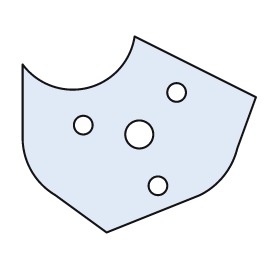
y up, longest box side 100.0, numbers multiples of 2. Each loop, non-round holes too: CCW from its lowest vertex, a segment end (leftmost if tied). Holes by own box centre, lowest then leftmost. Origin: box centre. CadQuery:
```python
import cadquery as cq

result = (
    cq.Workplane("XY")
    .moveTo(-14.0, -42.0)
    .lineTo(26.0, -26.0)
    .threePointArc((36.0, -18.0), (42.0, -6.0))
    .lineTo(50.0, 16.0)
    .lineTo(-2.0, 42.0)
    .threePointArc((-22.0, 20.0), (-50.0, 30.0))
    .lineTo(-50.0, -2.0)
    .threePointArc((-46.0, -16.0), (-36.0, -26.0))
    .close()
    .moveTo(8.0, -22.0)
    .circle(4.0)
    .moveTo(0.0, 0.0)
    .circle(6.0)
    .moveTo(-24.0, 4.0)
    .circle(4.0)
    .moveTo(16.0, 18.0)
    .circle(4.0)
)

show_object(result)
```